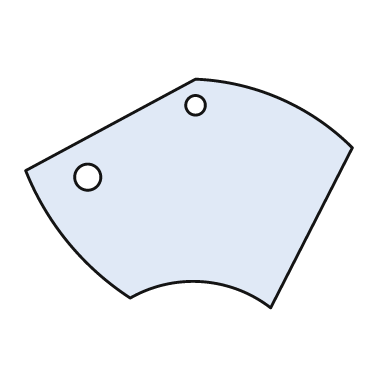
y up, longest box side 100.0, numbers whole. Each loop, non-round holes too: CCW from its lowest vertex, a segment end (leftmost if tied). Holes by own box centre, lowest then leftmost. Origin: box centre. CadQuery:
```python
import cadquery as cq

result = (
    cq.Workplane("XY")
    .moveTo(25.0, -35.0)
    .lineTo(50.0, 14.0)
    .threePointArc((28.0, 29.0), (2.0, 35.0))
    .lineTo(-50.0, 7.0)
    .threePointArc((-37.0, -15.0), (-18.0, -32.0))
    .threePointArc((4.0, -27.0), (25.0, -35.0))
    .close()
    .moveTo(-31.0, 5.0)
    .circle(4.0)
    .moveTo(2.0, 27.0)
    .circle(3.0)
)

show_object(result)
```